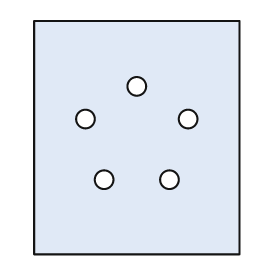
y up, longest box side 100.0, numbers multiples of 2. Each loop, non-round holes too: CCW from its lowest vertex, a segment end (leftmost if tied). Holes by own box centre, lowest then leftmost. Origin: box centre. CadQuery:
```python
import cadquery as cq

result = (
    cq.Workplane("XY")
    .moveTo(-44.0, -50.0)
    .lineTo(44.0, -50.0)
    .lineTo(44.0, 50.0)
    .lineTo(-44.0, 50.0)
    .close()
    .moveTo(-14.0, -18.0)
    .circle(4.0)
    .moveTo(14.0, -18.0)
    .circle(4.0)
    .moveTo(-22.0, 8.0)
    .circle(4.0)
    .moveTo(22.0, 8.0)
    .circle(4.0)
    .moveTo(0.0, 22.0)
    .circle(4.0)
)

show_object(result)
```